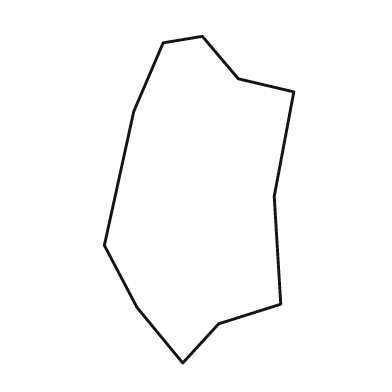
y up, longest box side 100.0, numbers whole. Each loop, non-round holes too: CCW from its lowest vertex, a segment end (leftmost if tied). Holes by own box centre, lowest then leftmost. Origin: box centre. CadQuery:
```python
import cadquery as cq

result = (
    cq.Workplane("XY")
    .moveTo(-5.0, -50.0)
    .lineTo(6.0, -38.0)
    .lineTo(25.0, -32.0)
    .lineTo(23.0, 1.0)
    .lineTo(29.0, 33.0)
    .lineTo(12.0, 37.0)
    .lineTo(1.0, 50.0)
    .lineTo(-11.0, 48.0)
    .lineTo(-20.0, 27.0)
    .lineTo(-29.0, -14.0)
    .lineTo(-19.0, -33.0)
    .close()
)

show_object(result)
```